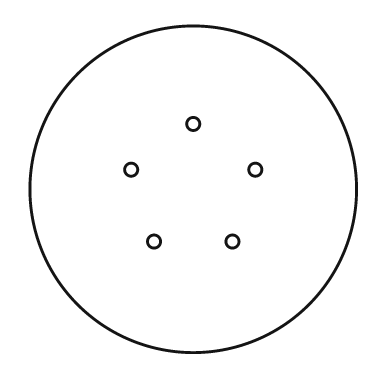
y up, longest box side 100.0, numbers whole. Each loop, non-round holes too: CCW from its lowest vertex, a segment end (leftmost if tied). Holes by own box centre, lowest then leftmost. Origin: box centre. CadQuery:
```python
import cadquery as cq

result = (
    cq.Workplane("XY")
    .moveTo(0.0, 0.0)
    .circle(50.0)
    .moveTo(-12.0, -16.0)
    .circle(2.0)
    .moveTo(12.0, -16.0)
    .circle(2.0)
    .moveTo(-19.0, 6.0)
    .circle(2.0)
    .moveTo(19.0, 6.0)
    .circle(2.0)
    .moveTo(0.0, 20.0)
    .circle(2.0)
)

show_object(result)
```